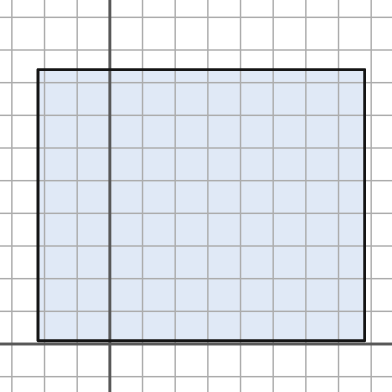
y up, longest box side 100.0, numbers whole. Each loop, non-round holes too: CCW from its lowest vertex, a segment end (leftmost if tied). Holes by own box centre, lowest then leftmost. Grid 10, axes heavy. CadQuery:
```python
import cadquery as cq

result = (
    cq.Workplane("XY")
    .moveTo(-22.0, 1.0)
    .lineTo(78.0, 1.0)
    .lineTo(78.0, 84.0)
    .lineTo(-22.0, 84.0)
    .close()
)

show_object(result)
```